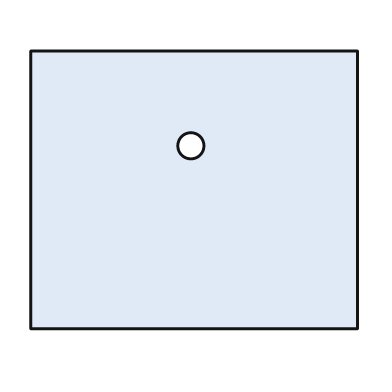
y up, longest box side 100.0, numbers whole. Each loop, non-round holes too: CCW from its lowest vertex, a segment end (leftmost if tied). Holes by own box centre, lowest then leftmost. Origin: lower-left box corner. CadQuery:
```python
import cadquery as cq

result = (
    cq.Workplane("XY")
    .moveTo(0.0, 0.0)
    .lineTo(100.0, 0.0)
    .lineTo(100.0, 85.0)
    .lineTo(0.0, 85.0)
    .close()
    .moveTo(49.0, 56.0)
    .circle(4.0)
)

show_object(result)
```